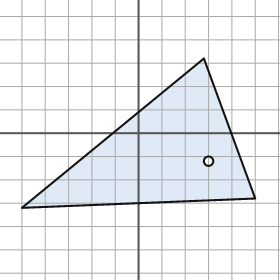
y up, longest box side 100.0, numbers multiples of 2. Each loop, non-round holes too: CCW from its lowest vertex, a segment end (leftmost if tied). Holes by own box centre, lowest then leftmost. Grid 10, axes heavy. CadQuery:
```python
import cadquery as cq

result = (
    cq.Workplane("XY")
    .moveTo(-50.0, -32.0)
    .lineTo(50.0, -28.0)
    .lineTo(28.0, 32.0)
    .close()
    .moveTo(30.0, -12.0)
    .circle(2.0)
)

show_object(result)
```